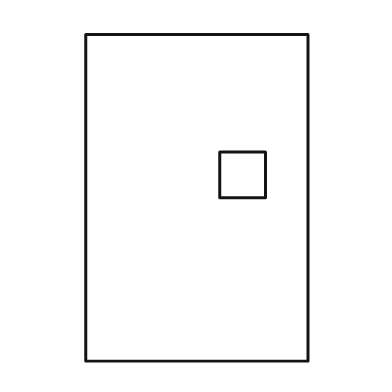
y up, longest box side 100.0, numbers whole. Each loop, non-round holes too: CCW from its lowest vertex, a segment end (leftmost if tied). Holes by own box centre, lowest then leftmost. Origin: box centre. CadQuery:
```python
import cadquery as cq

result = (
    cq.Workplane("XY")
    .moveTo(-34.0, -50.0)
    .lineTo(34.0, -50.0)
    .lineTo(34.0, 50.0)
    .lineTo(-34.0, 50.0)
    .close()
    .moveTo(7.0, 0.0)
    .lineTo(21.0, 0.0)
    .lineTo(21.0, 14.0)
    .lineTo(7.0, 14.0)
    .close()
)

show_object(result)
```